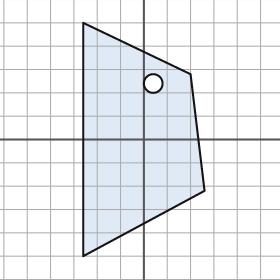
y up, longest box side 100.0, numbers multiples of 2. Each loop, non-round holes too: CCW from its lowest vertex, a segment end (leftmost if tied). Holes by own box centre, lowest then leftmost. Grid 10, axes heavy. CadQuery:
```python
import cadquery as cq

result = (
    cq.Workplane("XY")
    .moveTo(-26.0, -50.0)
    .lineTo(26.0, -22.0)
    .lineTo(20.0, 28.0)
    .lineTo(-26.0, 50.0)
    .close()
    .moveTo(4.0, 24.0)
    .circle(4.0)
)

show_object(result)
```